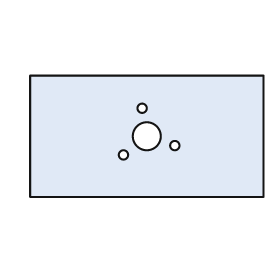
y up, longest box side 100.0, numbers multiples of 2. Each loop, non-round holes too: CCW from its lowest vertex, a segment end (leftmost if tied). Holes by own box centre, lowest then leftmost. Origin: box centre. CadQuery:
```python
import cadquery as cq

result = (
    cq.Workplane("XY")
    .moveTo(-50.0, -26.0)
    .lineTo(50.0, -26.0)
    .lineTo(50.0, 26.0)
    .lineTo(-50.0, 26.0)
    .close()
    .moveTo(-10.0, -8.0)
    .circle(2.0)
    .moveTo(12.0, -4.0)
    .circle(2.0)
    .moveTo(0.0, 0.0)
    .circle(6.0)
    .moveTo(-2.0, 12.0)
    .circle(2.0)
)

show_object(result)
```